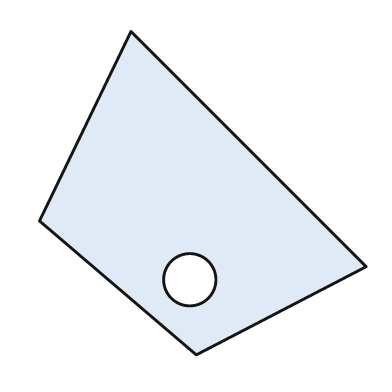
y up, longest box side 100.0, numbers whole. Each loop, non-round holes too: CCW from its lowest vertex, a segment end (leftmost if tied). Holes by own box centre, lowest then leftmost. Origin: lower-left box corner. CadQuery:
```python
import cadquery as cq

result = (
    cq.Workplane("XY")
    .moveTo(48.0, 0.0)
    .lineTo(100.0, 27.0)
    .lineTo(28.0, 99.0)
    .lineTo(0.0, 41.0)
    .close()
    .moveTo(46.0, 23.0)
    .circle(8.0)
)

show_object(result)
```